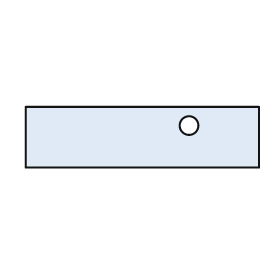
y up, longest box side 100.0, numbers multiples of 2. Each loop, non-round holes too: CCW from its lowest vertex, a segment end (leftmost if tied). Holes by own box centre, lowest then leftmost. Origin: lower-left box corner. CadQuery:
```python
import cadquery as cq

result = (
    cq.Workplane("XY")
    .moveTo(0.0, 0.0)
    .lineTo(100.0, 0.0)
    .lineTo(100.0, 26.0)
    .lineTo(0.0, 26.0)
    .close()
    .moveTo(70.0, 18.0)
    .circle(4.0)
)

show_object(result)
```